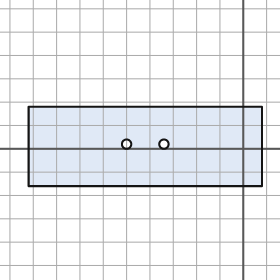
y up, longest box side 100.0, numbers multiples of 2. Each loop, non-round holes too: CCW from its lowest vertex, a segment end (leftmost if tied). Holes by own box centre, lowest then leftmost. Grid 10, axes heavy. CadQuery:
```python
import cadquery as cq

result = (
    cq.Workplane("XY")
    .moveTo(-92.0, -16.0)
    .lineTo(8.0, -16.0)
    .lineTo(8.0, 18.0)
    .lineTo(-92.0, 18.0)
    .close()
    .moveTo(-50.0, 2.0)
    .circle(2.0)
    .moveTo(-34.0, 2.0)
    .circle(2.0)
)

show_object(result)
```